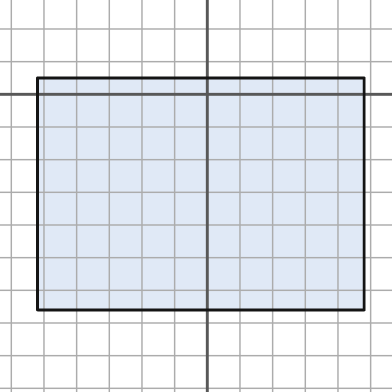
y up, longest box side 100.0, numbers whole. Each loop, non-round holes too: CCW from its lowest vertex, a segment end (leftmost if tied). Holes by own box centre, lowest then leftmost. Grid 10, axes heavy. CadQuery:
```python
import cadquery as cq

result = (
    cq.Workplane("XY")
    .moveTo(-52.0, -66.0)
    .lineTo(48.0, -66.0)
    .lineTo(48.0, 5.0)
    .lineTo(-52.0, 5.0)
    .close()
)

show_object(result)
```